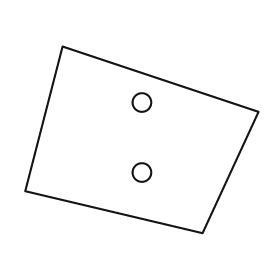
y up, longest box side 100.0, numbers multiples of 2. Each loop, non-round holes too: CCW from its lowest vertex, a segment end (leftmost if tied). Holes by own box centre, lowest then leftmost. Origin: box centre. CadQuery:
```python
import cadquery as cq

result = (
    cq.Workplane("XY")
    .moveTo(26.0, -40.0)
    .lineTo(50.0, 12.0)
    .lineTo(-34.0, 40.0)
    .lineTo(-50.0, -22.0)
    .close()
    .moveTo(0.0, -14.0)
    .circle(4.0)
    .moveTo(0.0, 16.0)
    .circle(4.0)
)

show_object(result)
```